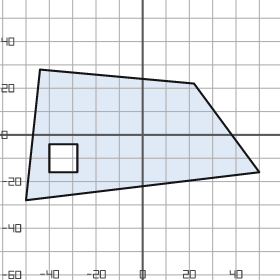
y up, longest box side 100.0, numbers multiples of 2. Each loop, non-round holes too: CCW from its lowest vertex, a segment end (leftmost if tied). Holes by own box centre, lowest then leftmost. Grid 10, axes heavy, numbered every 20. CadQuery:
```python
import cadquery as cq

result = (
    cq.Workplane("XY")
    .moveTo(-50.0, -28.0)
    .lineTo(50.0, -16.0)
    .lineTo(22.0, 22.0)
    .lineTo(-44.0, 28.0)
    .close()
    .moveTo(-40.0, -16.0)
    .lineTo(-28.0, -16.0)
    .lineTo(-28.0, -4.0)
    .lineTo(-40.0, -4.0)
    .close()
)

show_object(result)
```